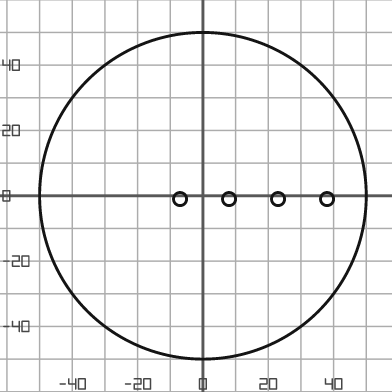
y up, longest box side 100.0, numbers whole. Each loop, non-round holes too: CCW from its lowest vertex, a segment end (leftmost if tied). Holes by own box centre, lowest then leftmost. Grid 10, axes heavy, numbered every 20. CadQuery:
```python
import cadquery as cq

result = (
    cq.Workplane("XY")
    .moveTo(0.0, 0.0)
    .circle(50.0)
    .moveTo(-7.0, -1.0)
    .circle(2.0)
    .moveTo(8.0, -1.0)
    .circle(2.0)
    .moveTo(23.0, -1.0)
    .circle(2.0)
    .moveTo(38.0, -1.0)
    .circle(2.0)
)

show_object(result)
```